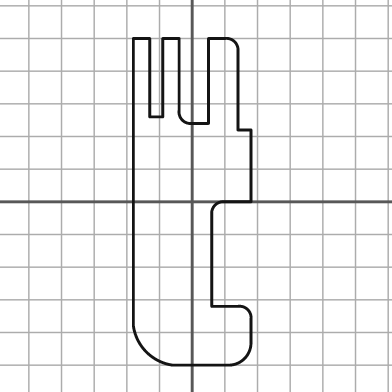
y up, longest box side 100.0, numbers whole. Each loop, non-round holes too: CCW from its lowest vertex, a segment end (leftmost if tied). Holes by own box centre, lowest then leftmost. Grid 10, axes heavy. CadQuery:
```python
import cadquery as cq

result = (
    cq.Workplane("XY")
    .moveTo(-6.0, -50.0)
    .lineTo(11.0, -50.0)
    .threePointArc((16.0, -48.0), (18.0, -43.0))
    .lineTo(18.0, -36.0)
    .threePointArc((17.0, -33.0), (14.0, -32.0))
    .lineTo(6.0, -32.0)
    .lineTo(6.0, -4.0)
    .threePointArc((7.0, -1.0), (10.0, 0.0))
    .lineTo(18.0, 0.0)
    .lineTo(18.0, 22.0)
    .lineTo(14.0, 22.0)
    .lineTo(14.0, 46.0)
    .threePointArc((13.0, 49.0), (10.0, 50.0))
    .lineTo(5.0, 50.0)
    .lineTo(5.0, 24.0)
    .lineTo(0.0, 24.0)
    .threePointArc((-3.0, 25.0), (-4.0, 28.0))
    .lineTo(-4.0, 50.0)
    .lineTo(-9.0, 50.0)
    .lineTo(-9.0, 26.0)
    .lineTo(-13.0, 26.0)
    .lineTo(-13.0, 50.0)
    .lineTo(-18.0, 50.0)
    .lineTo(-18.0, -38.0)
    .threePointArc((-14.0, -46.0), (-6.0, -50.0))
    .close()
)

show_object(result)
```